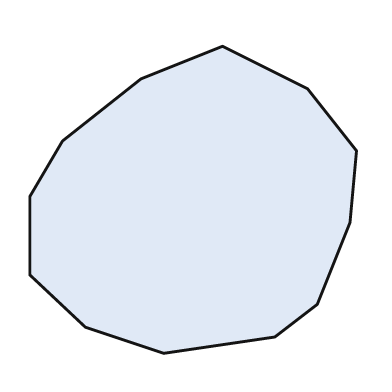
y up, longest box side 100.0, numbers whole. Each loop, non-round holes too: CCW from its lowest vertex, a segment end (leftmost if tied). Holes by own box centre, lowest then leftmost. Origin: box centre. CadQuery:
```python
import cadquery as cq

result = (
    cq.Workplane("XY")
    .moveTo(-9.0, -47.0)
    .lineTo(25.0, -42.0)
    .lineTo(38.0, -32.0)
    .lineTo(48.0, -7.0)
    .lineTo(50.0, 15.0)
    .lineTo(35.0, 34.0)
    .lineTo(9.0, 47.0)
    .lineTo(-16.0, 37.0)
    .lineTo(-40.0, 18.0)
    .lineTo(-50.0, 1.0)
    .lineTo(-50.0, -23.0)
    .lineTo(-33.0, -39.0)
    .close()
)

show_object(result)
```